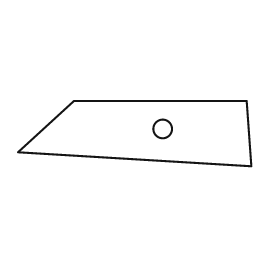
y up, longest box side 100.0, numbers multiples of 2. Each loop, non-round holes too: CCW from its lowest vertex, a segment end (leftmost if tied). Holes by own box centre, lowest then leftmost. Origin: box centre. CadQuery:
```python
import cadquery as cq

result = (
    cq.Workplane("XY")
    .moveTo(50.0, -14.0)
    .lineTo(48.0, 14.0)
    .lineTo(-26.0, 14.0)
    .lineTo(-50.0, -8.0)
    .close()
    .moveTo(12.0, 2.0)
    .circle(4.0)
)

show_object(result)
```